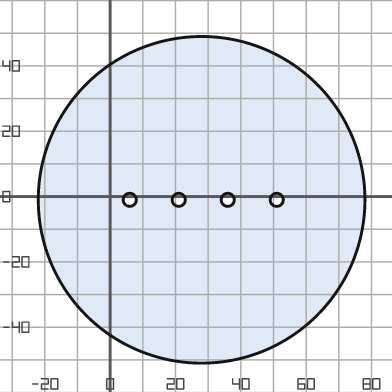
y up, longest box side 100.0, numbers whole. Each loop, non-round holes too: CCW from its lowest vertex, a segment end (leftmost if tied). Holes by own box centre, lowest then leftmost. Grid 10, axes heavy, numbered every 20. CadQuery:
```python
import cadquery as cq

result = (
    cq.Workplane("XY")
    .moveTo(28.0, -1.0)
    .circle(50.0)
    .moveTo(6.0, -1.0)
    .circle(2.0)
    .moveTo(21.0, -1.0)
    .circle(2.0)
    .moveTo(36.0, -1.0)
    .circle(2.0)
    .moveTo(51.0, -1.0)
    .circle(2.0)
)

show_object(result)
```